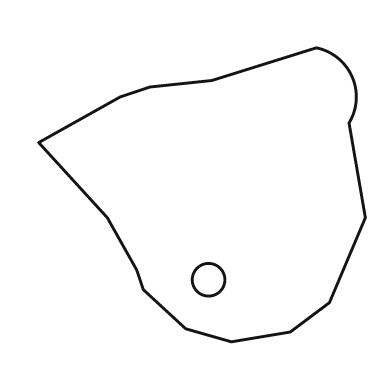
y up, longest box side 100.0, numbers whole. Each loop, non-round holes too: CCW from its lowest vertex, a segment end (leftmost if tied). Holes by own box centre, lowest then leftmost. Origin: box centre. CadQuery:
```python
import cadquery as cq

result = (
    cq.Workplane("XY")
    .moveTo(9.0, -45.0)
    .lineTo(27.0, -42.0)
    .lineTo(39.0, -33.0)
    .lineTo(50.0, -7.0)
    .lineTo(45.0, 22.0)
    .threePointArc((46.0, 36.0), (35.0, 45.0))
    .lineTo(3.0, 35.0)
    .lineTo(-16.0, 33.0)
    .lineTo(-25.0, 30.0)
    .lineTo(-50.0, 16.0)
    .lineTo(-29.0, -7.0)
    .lineTo(-20.0, -23.0)
    .lineTo(-18.0, -29.0)
    .lineTo(-5.0, -41.0)
    .close()
    .moveTo(2.0, -26.0)
    .circle(5.0)
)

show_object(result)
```